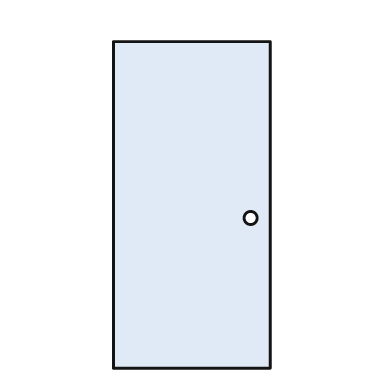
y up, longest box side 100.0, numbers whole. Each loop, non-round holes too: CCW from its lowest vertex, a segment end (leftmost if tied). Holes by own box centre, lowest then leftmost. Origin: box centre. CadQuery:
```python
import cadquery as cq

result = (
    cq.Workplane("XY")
    .moveTo(-24.0, -50.0)
    .lineTo(24.0, -50.0)
    .lineTo(24.0, 50.0)
    .lineTo(-24.0, 50.0)
    .close()
    .moveTo(18.0, -4.0)
    .circle(2.0)
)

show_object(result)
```